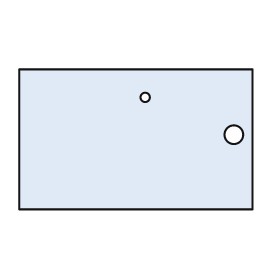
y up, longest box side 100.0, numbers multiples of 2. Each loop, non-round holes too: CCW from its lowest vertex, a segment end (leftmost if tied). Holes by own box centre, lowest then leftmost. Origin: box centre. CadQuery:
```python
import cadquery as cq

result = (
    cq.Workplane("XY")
    .moveTo(-50.0, -30.0)
    .lineTo(50.0, -30.0)
    .lineTo(50.0, 30.0)
    .lineTo(-50.0, 30.0)
    .close()
    .moveTo(42.0, 2.0)
    .circle(4.0)
    .moveTo(4.0, 18.0)
    .circle(2.0)
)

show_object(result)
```